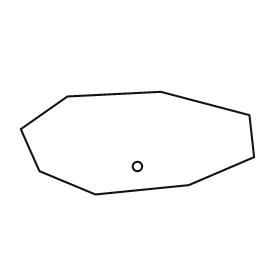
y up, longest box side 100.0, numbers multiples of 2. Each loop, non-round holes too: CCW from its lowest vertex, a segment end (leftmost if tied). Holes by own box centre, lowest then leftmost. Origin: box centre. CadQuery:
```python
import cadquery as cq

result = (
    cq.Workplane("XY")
    .moveTo(-18.0, -22.0)
    .lineTo(22.0, -18.0)
    .lineTo(50.0, -6.0)
    .lineTo(48.0, 12.0)
    .lineTo(10.0, 22.0)
    .lineTo(-30.0, 20.0)
    .lineTo(-50.0, 6.0)
    .lineTo(-42.0, -12.0)
    .close()
    .moveTo(0.0, -10.0)
    .circle(2.0)
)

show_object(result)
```